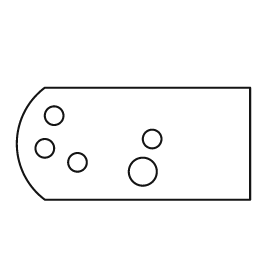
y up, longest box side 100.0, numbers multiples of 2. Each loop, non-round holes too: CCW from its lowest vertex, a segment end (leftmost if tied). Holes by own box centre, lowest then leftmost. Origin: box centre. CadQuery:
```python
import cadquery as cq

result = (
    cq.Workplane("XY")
    .moveTo(-38.0, -24.0)
    .lineTo(50.0, -24.0)
    .lineTo(50.0, 24.0)
    .lineTo(-38.0, 24.0)
    .threePointArc((-50.0, 0.0), (-38.0, -24.0))
    .close()
    .moveTo(4.0, -12.0)
    .circle(6.0)
    .moveTo(-24.0, -8.0)
    .circle(4.0)
    .moveTo(-38.0, -2.0)
    .circle(4.0)
    .moveTo(8.0, 2.0)
    .circle(4.0)
    .moveTo(-34.0, 12.0)
    .circle(4.0)
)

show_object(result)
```